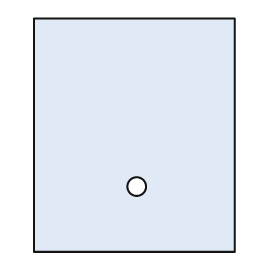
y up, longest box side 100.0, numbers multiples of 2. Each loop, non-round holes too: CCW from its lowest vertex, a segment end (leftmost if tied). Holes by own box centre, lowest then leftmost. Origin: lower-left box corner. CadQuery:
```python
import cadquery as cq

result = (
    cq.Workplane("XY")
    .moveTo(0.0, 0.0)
    .lineTo(86.0, 0.0)
    .lineTo(86.0, 100.0)
    .lineTo(0.0, 100.0)
    .close()
    .moveTo(44.0, 28.0)
    .circle(4.0)
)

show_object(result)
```